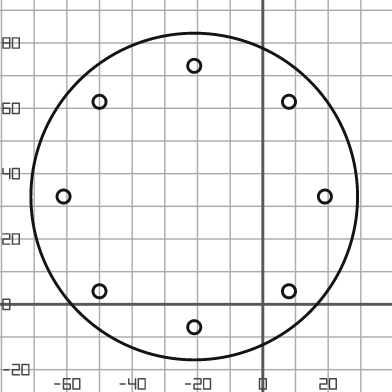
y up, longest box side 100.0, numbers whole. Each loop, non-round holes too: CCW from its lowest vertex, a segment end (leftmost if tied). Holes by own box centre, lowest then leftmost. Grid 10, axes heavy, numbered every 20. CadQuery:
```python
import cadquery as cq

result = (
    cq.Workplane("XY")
    .moveTo(-21.0, 33.0)
    .circle(50.0)
    .moveTo(-21.0, -7.0)
    .circle(2.0)
    .moveTo(-50.0, 4.0)
    .circle(2.0)
    .moveTo(8.0, 4.0)
    .circle(2.0)
    .moveTo(-61.0, 33.0)
    .circle(2.0)
    .moveTo(19.0, 33.0)
    .circle(2.0)
    .moveTo(-50.0, 62.0)
    .circle(2.0)
    .moveTo(8.0, 62.0)
    .circle(2.0)
    .moveTo(-21.0, 73.0)
    .circle(2.0)
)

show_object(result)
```